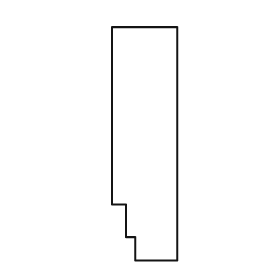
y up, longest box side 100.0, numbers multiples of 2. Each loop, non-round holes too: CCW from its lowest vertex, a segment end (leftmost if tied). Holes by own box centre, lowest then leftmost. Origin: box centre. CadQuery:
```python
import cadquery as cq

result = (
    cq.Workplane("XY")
    .moveTo(-4.0, -50.0)
    .lineTo(14.0, -50.0)
    .lineTo(14.0, 50.0)
    .lineTo(-14.0, 50.0)
    .lineTo(-14.0, -26.0)
    .lineTo(-8.0, -26.0)
    .lineTo(-8.0, -40.0)
    .lineTo(-4.0, -40.0)
    .close()
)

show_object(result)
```